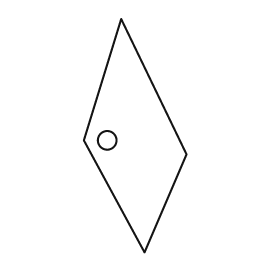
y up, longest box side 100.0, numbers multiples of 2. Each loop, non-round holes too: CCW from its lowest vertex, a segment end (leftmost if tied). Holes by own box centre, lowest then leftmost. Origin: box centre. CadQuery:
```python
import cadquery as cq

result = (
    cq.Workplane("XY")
    .moveTo(4.0, -50.0)
    .lineTo(22.0, -8.0)
    .lineTo(-6.0, 50.0)
    .lineTo(-22.0, -2.0)
    .close()
    .moveTo(-12.0, -2.0)
    .circle(4.0)
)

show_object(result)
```